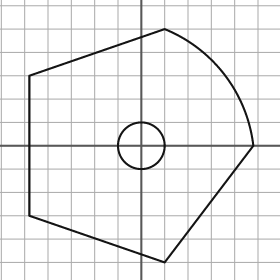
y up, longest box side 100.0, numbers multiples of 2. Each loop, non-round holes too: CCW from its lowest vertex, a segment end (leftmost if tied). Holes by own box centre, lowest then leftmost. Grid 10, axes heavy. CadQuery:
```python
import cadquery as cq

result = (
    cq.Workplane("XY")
    .moveTo(10.0, -50.0)
    .lineTo(48.0, 0.0)
    .threePointArc((36.0, 30.0), (10.0, 50.0))
    .lineTo(-48.0, 30.0)
    .lineTo(-48.0, -30.0)
    .close()
    .moveTo(0.0, 0.0)
    .circle(10.0)
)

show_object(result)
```